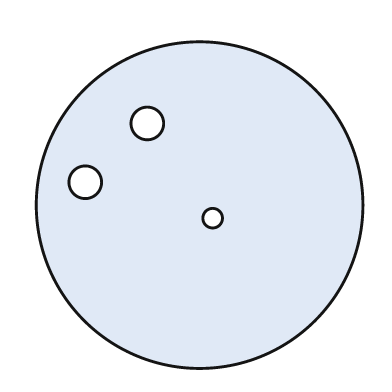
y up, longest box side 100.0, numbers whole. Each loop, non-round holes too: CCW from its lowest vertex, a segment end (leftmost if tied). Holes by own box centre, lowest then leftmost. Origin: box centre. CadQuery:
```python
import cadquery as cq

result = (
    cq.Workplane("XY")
    .moveTo(0.0, 0.0)
    .circle(50.0)
    .moveTo(4.0, -4.0)
    .circle(3.0)
    .moveTo(-35.0, 7.0)
    .circle(5.0)
    .moveTo(-16.0, 25.0)
    .circle(5.0)
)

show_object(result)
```